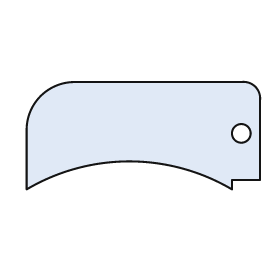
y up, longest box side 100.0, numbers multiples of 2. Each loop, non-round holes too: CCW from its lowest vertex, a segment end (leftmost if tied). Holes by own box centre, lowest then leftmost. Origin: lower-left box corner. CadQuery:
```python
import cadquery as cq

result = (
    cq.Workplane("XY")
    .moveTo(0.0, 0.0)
    .threePointArc((44.0, 12.0), (88.0, 0.0))
    .lineTo(88.0, 4.0)
    .lineTo(100.0, 4.0)
    .lineTo(100.0, 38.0)
    .threePointArc((98.0, 44.0), (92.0, 46.0))
    .lineTo(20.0, 46.0)
    .threePointArc((6.0, 40.0), (0.0, 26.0))
    .close()
    .moveTo(92.0, 24.0)
    .circle(4.0)
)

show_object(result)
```